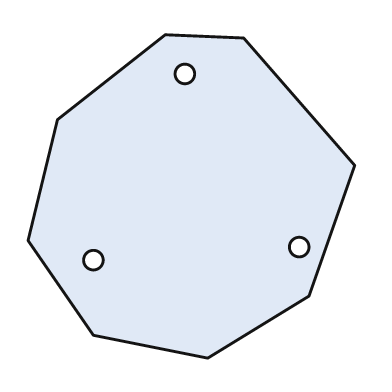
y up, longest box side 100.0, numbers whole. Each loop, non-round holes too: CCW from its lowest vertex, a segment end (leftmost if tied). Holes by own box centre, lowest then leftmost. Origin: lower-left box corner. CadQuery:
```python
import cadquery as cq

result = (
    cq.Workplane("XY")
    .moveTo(55.0, 0.0)
    .lineTo(86.0, 19.0)
    .lineTo(100.0, 59.0)
    .lineTo(66.0, 98.0)
    .lineTo(42.0, 99.0)
    .lineTo(9.0, 73.0)
    .lineTo(0.0, 36.0)
    .lineTo(20.0, 7.0)
    .close()
    .moveTo(20.0, 30.0)
    .circle(3.0)
    .moveTo(83.0, 34.0)
    .circle(3.0)
    .moveTo(48.0, 87.0)
    .circle(3.0)
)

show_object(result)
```